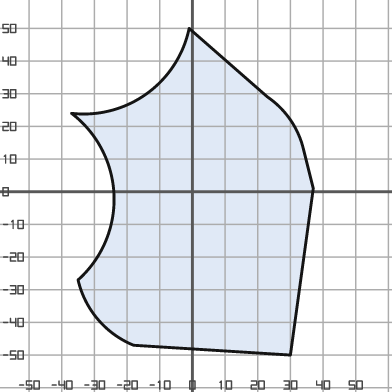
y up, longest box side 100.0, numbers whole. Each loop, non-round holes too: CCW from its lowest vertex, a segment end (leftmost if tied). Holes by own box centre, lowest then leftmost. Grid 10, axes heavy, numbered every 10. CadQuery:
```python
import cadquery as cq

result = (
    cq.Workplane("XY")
    .moveTo(30.0, -50.0)
    .lineTo(37.0, 1.0)
    .lineTo(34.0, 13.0)
    .threePointArc((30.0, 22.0), (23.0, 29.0))
    .lineTo(-1.0, 50.0)
    .threePointArc((-14.0, 30.0), (-37.0, 24.0))
    .threePointArc((-24.0, -1.0), (-35.0, -27.0))
    .threePointArc((-29.0, -39.0), (-18.0, -47.0))
    .close()
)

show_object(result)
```